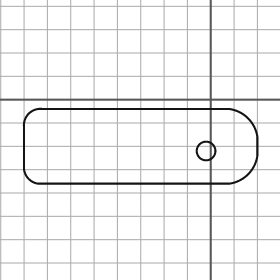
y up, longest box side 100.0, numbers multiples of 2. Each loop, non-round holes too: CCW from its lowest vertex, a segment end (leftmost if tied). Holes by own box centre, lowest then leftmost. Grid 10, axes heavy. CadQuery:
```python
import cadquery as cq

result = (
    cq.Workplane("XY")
    .moveTo(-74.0, -36.0)
    .lineTo(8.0, -36.0)
    .threePointArc((16.0, -32.0), (20.0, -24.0))
    .lineTo(20.0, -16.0)
    .threePointArc((16.0, -8.0), (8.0, -4.0))
    .lineTo(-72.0, -4.0)
    .threePointArc((-78.0, -6.0), (-80.0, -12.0))
    .lineTo(-80.0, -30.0)
    .threePointArc((-78.0, -34.0), (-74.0, -36.0))
    .close()
    .moveTo(-2.0, -22.0)
    .circle(4.0)
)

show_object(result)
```